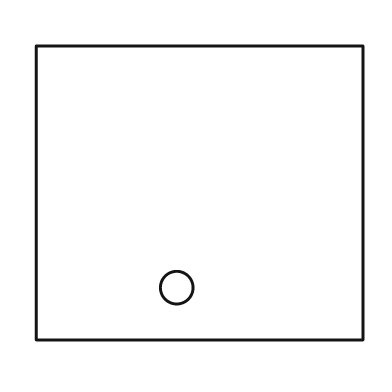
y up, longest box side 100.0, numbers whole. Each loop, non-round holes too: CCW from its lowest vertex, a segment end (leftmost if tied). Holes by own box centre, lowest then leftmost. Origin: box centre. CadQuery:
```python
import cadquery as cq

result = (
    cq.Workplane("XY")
    .moveTo(-50.0, -45.0)
    .lineTo(50.0, -45.0)
    .lineTo(50.0, 45.0)
    .lineTo(-50.0, 45.0)
    .close()
    .moveTo(-7.0, -29.0)
    .circle(5.0)
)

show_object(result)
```